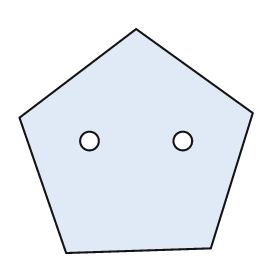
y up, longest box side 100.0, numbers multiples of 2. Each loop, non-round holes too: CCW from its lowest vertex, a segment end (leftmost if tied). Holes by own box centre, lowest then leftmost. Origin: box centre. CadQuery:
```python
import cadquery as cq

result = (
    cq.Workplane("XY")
    .moveTo(-30.0, -48.0)
    .lineTo(32.0, -46.0)
    .lineTo(50.0, 12.0)
    .lineTo(0.0, 48.0)
    .lineTo(-50.0, 10.0)
    .close()
    .moveTo(-20.0, 0.0)
    .circle(4.0)
    .moveTo(20.0, 0.0)
    .circle(4.0)
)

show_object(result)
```